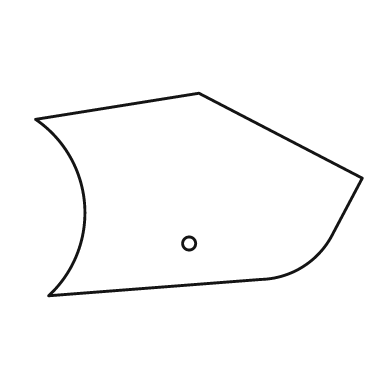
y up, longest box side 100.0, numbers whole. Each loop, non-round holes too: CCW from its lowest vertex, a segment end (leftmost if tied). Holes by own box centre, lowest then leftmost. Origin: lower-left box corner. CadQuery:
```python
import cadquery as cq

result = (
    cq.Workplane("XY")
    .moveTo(4.0, 0.0)
    .lineTo(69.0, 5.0)
    .threePointArc((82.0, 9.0), (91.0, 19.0))
    .lineTo(100.0, 36.0)
    .lineTo(50.0, 62.0)
    .lineTo(0.0, 54.0)
    .threePointArc((15.0, 28.0), (4.0, 0.0))
    .close()
    .moveTo(47.0, 16.0)
    .circle(2.0)
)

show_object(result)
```